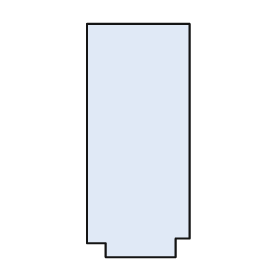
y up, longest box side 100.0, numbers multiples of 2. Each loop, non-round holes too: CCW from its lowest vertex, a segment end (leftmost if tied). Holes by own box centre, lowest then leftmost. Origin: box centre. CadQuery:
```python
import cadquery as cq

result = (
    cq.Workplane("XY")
    .moveTo(-14.0, -50.0)
    .lineTo(16.0, -50.0)
    .lineTo(16.0, -42.0)
    .lineTo(22.0, -42.0)
    .lineTo(22.0, 50.0)
    .lineTo(-22.0, 50.0)
    .lineTo(-22.0, -44.0)
    .lineTo(-14.0, -44.0)
    .close()
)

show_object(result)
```